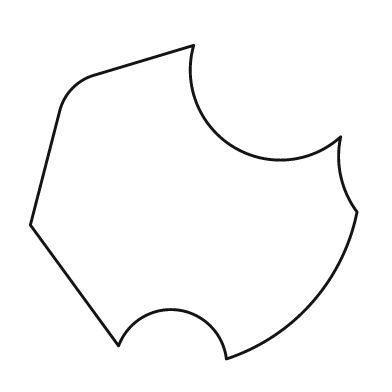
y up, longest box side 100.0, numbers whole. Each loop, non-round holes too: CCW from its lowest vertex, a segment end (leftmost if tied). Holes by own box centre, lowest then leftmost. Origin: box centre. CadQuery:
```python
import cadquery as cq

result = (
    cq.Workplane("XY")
    .moveTo(10.0, -48.0)
    .threePointArc((36.0, -31.0), (50.0, -3.0))
    .threePointArc((45.0, 8.0), (45.0, 20.0))
    .threePointArc((12.0, 17.0), (0.0, 48.0))
    .lineTo(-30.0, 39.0)
    .threePointArc((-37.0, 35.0), (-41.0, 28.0))
    .lineTo(-50.0, -7.0)
    .lineTo(-23.0, -44.0)
    .threePointArc((-5.0, -33.0), (10.0, -48.0))
    .close()
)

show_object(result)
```